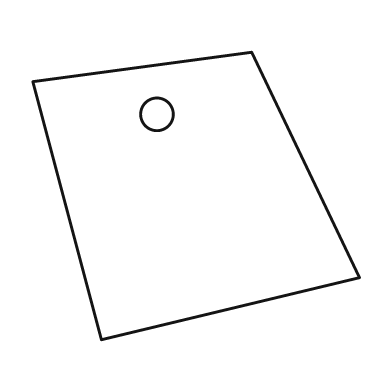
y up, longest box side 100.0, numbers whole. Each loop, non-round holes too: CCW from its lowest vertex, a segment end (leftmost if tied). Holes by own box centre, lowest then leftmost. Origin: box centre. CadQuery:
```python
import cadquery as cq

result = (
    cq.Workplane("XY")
    .moveTo(-29.0, -44.0)
    .lineTo(50.0, -25.0)
    .lineTo(17.0, 44.0)
    .lineTo(-50.0, 35.0)
    .close()
    .moveTo(-12.0, 25.0)
    .circle(5.0)
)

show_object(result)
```